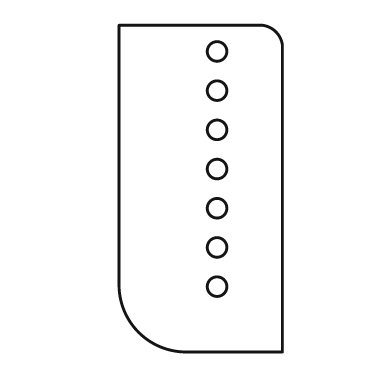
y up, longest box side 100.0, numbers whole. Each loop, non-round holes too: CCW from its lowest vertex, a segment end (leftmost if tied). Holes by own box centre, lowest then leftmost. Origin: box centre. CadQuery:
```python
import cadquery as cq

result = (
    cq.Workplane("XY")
    .moveTo(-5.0, -50.0)
    .lineTo(25.0, -50.0)
    .lineTo(25.0, 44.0)
    .threePointArc((23.0, 48.0), (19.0, 50.0))
    .lineTo(-25.0, 50.0)
    .lineTo(-25.0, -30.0)
    .threePointArc((-19.0, -44.0), (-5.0, -50.0))
    .close()
    .moveTo(5.0, -30.0)
    .circle(3.0)
    .moveTo(5.0, -18.0)
    .circle(3.0)
    .moveTo(5.0, -6.0)
    .circle(3.0)
    .moveTo(5.0, 6.0)
    .circle(3.0)
    .moveTo(5.0, 18.0)
    .circle(3.0)
    .moveTo(5.0, 30.0)
    .circle(3.0)
    .moveTo(5.0, 42.0)
    .circle(3.0)
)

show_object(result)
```